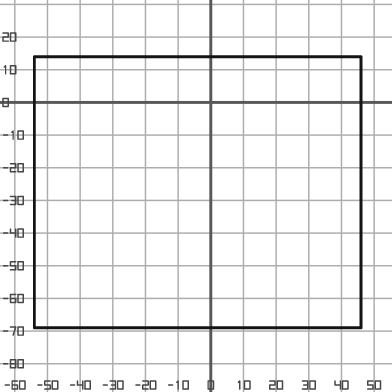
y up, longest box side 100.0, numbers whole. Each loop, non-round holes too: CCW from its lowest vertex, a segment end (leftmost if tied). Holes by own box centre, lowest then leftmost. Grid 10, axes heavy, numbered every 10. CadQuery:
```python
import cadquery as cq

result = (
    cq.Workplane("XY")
    .moveTo(-54.0, -69.0)
    .lineTo(46.0, -69.0)
    .lineTo(46.0, 14.0)
    .lineTo(-54.0, 14.0)
    .close()
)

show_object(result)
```